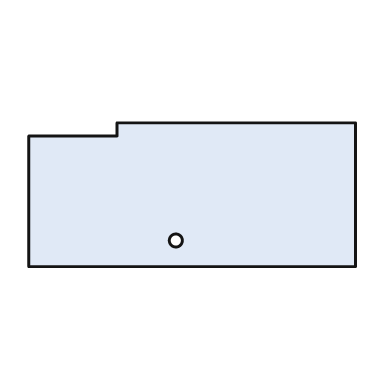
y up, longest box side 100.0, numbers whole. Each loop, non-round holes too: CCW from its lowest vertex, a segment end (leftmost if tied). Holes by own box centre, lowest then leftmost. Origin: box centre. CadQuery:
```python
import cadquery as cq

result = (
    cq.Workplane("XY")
    .moveTo(-50.0, -22.0)
    .lineTo(50.0, -22.0)
    .lineTo(50.0, 22.0)
    .lineTo(-23.0, 22.0)
    .lineTo(-23.0, 18.0)
    .lineTo(-50.0, 18.0)
    .close()
    .moveTo(-5.0, -14.0)
    .circle(2.0)
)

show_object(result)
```